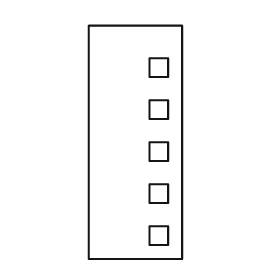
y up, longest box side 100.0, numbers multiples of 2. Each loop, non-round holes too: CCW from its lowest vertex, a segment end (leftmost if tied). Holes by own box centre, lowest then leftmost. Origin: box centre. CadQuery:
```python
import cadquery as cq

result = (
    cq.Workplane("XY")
    .moveTo(-20.0, -50.0)
    .lineTo(20.0, -50.0)
    .lineTo(20.0, 50.0)
    .lineTo(-20.0, 50.0)
    .close()
    .moveTo(6.0, -44.0)
    .lineTo(14.0, -44.0)
    .lineTo(14.0, -36.0)
    .lineTo(6.0, -36.0)
    .close()
    .moveTo(6.0, -26.0)
    .lineTo(14.0, -26.0)
    .lineTo(14.0, -18.0)
    .lineTo(6.0, -18.0)
    .close()
    .moveTo(6.0, -8.0)
    .lineTo(14.0, -8.0)
    .lineTo(14.0, 0.0)
    .lineTo(6.0, 0.0)
    .close()
    .moveTo(6.0, 10.0)
    .lineTo(14.0, 10.0)
    .lineTo(14.0, 18.0)
    .lineTo(6.0, 18.0)
    .close()
    .moveTo(6.0, 28.0)
    .lineTo(14.0, 28.0)
    .lineTo(14.0, 36.0)
    .lineTo(6.0, 36.0)
    .close()
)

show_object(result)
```